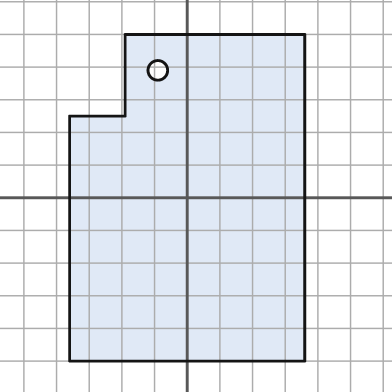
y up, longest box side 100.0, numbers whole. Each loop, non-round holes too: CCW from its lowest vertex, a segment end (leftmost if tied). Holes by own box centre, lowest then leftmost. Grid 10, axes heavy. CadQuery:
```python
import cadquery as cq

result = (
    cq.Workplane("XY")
    .moveTo(-36.0, -50.0)
    .lineTo(36.0, -50.0)
    .lineTo(36.0, 50.0)
    .lineTo(-19.0, 50.0)
    .lineTo(-19.0, 25.0)
    .lineTo(-36.0, 25.0)
    .close()
    .moveTo(-9.0, 39.0)
    .circle(3.0)
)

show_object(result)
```